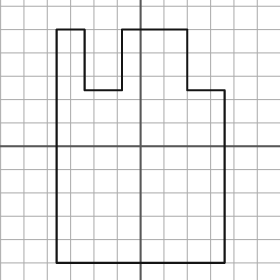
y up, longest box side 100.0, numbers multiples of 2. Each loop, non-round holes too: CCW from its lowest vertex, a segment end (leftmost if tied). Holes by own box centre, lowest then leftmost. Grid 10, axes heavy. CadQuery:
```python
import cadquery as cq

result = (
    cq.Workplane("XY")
    .moveTo(-36.0, -50.0)
    .lineTo(36.0, -50.0)
    .lineTo(36.0, 24.0)
    .lineTo(20.0, 24.0)
    .lineTo(20.0, 50.0)
    .lineTo(-8.0, 50.0)
    .lineTo(-8.0, 24.0)
    .lineTo(-24.0, 24.0)
    .lineTo(-24.0, 50.0)
    .lineTo(-36.0, 50.0)
    .close()
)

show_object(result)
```